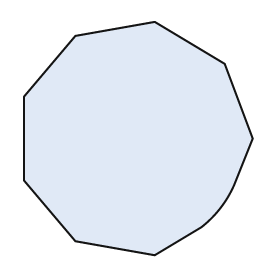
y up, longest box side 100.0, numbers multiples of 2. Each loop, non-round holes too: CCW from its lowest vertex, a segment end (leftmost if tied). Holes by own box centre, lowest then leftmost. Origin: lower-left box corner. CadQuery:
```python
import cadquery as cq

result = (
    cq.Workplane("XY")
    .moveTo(56.0, 0.0)
    .lineTo(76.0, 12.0)
    .threePointArc((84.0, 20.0), (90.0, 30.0))
    .lineTo(98.0, 50.0)
    .lineTo(86.0, 82.0)
    .lineTo(56.0, 100.0)
    .lineTo(22.0, 94.0)
    .lineTo(0.0, 68.0)
    .lineTo(0.0, 32.0)
    .lineTo(22.0, 6.0)
    .close()
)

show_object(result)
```